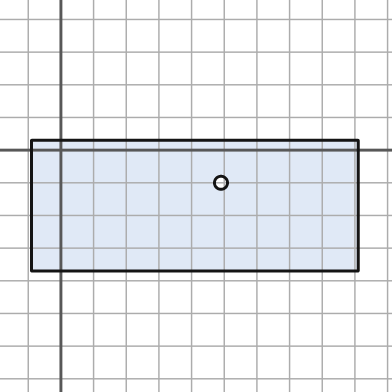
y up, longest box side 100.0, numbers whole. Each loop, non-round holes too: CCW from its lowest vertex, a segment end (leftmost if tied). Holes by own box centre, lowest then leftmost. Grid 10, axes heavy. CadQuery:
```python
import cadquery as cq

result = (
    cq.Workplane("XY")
    .moveTo(-9.0, -37.0)
    .lineTo(91.0, -37.0)
    .lineTo(91.0, 3.0)
    .lineTo(-9.0, 3.0)
    .close()
    .moveTo(49.0, -10.0)
    .circle(2.0)
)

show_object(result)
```